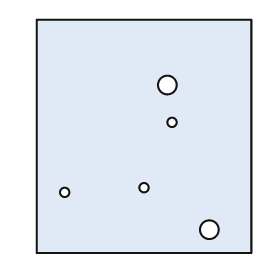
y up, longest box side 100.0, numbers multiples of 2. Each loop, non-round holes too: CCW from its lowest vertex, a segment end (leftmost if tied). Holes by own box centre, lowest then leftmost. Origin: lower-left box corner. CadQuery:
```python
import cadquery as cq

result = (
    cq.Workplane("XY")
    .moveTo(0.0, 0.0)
    .lineTo(92.0, 0.0)
    .lineTo(92.0, 100.0)
    .lineTo(0.0, 100.0)
    .close()
    .moveTo(74.0, 10.0)
    .circle(4.0)
    .moveTo(12.0, 26.0)
    .circle(2.0)
    .moveTo(46.0, 28.0)
    .circle(2.0)
    .moveTo(58.0, 56.0)
    .circle(2.0)
    .moveTo(56.0, 72.0)
    .circle(4.0)
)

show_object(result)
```